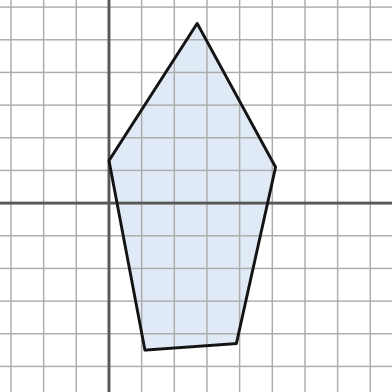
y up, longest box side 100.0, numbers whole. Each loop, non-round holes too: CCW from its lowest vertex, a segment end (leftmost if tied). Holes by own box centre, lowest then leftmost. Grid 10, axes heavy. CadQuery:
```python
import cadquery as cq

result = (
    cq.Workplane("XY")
    .moveTo(11.0, -45.0)
    .lineTo(39.0, -43.0)
    .lineTo(51.0, 11.0)
    .lineTo(27.0, 55.0)
    .lineTo(0.0, 13.0)
    .close()
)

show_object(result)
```